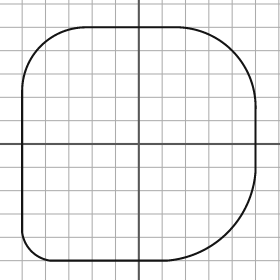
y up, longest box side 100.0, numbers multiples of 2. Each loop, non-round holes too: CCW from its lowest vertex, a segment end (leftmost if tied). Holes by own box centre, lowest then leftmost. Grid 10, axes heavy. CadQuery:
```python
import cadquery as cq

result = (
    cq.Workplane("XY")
    .moveTo(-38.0, -50.0)
    .lineTo(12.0, -50.0)
    .threePointArc((38.0, -38.0), (50.0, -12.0))
    .lineTo(50.0, 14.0)
    .threePointArc((40.0, 40.0), (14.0, 50.0))
    .lineTo(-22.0, 50.0)
    .threePointArc((-42.0, 42.0), (-50.0, 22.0))
    .lineTo(-50.0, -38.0)
    .threePointArc((-46.0, -46.0), (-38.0, -50.0))
    .close()
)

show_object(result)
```